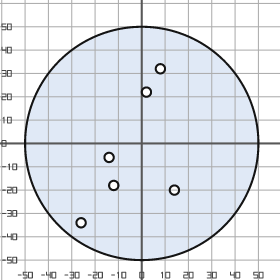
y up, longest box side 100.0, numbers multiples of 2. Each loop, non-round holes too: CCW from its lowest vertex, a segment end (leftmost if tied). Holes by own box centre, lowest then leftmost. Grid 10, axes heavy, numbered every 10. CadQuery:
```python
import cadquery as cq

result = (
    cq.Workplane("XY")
    .moveTo(0.0, 0.0)
    .circle(50.0)
    .moveTo(-26.0, -34.0)
    .circle(2.0)
    .moveTo(14.0, -20.0)
    .circle(2.0)
    .moveTo(-12.0, -18.0)
    .circle(2.0)
    .moveTo(-14.0, -6.0)
    .circle(2.0)
    .moveTo(2.0, 22.0)
    .circle(2.0)
    .moveTo(8.0, 32.0)
    .circle(2.0)
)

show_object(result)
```